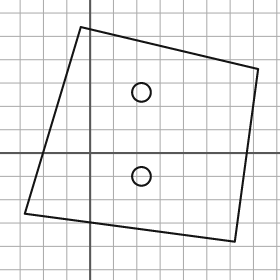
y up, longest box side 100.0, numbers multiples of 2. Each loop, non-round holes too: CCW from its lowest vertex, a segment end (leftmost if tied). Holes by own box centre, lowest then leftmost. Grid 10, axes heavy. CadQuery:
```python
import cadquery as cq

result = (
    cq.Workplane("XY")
    .moveTo(62.0, -38.0)
    .lineTo(72.0, 36.0)
    .lineTo(-4.0, 54.0)
    .lineTo(-28.0, -26.0)
    .close()
    .moveTo(22.0, -10.0)
    .circle(4.0)
    .moveTo(22.0, 26.0)
    .circle(4.0)
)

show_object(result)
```